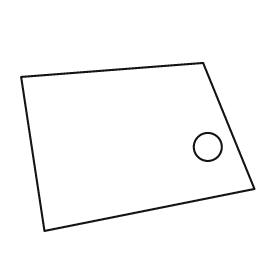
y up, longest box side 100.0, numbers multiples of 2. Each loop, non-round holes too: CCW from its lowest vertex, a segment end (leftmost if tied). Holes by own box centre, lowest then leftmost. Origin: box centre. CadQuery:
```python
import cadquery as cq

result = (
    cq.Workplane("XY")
    .moveTo(-40.0, -36.0)
    .lineTo(50.0, -18.0)
    .lineTo(28.0, 36.0)
    .lineTo(-50.0, 30.0)
    .close()
    .moveTo(30.0, 0.0)
    .circle(6.0)
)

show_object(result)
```